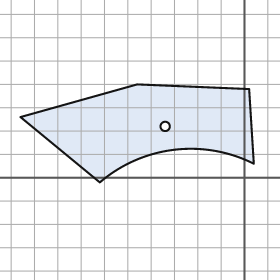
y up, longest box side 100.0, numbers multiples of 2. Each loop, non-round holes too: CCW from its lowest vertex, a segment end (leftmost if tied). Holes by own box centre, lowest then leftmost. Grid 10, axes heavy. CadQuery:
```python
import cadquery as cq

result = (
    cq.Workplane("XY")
    .moveTo(-62.0, -2.0)
    .threePointArc((-30.0, 12.0), (4.0, 6.0))
    .lineTo(2.0, 38.0)
    .lineTo(-46.0, 40.0)
    .lineTo(-96.0, 26.0)
    .close()
    .moveTo(-34.0, 22.0)
    .circle(2.0)
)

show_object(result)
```